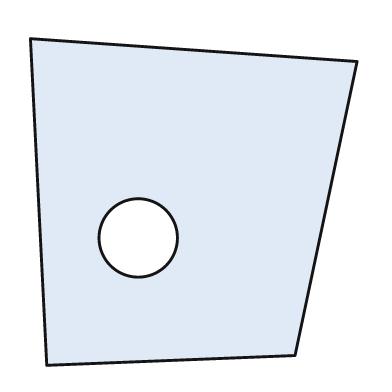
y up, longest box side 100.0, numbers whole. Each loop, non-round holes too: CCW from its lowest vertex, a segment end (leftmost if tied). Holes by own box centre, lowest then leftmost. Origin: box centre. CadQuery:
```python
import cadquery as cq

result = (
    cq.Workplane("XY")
    .moveTo(-45.0, -50.0)
    .lineTo(31.0, -47.0)
    .lineTo(50.0, 43.0)
    .lineTo(-50.0, 50.0)
    .close()
    .moveTo(-17.0, -11.0)
    .circle(12.0)
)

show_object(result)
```